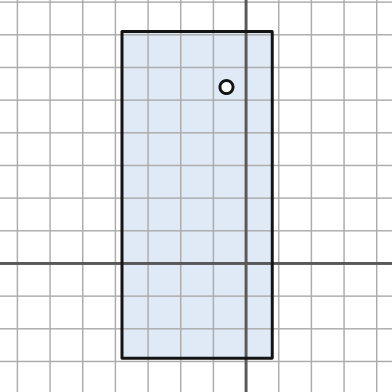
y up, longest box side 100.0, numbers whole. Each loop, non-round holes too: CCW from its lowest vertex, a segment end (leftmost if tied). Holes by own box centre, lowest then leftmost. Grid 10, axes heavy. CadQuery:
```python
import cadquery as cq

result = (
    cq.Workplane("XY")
    .moveTo(-38.0, -29.0)
    .lineTo(8.0, -29.0)
    .lineTo(8.0, 71.0)
    .lineTo(-38.0, 71.0)
    .close()
    .moveTo(-6.0, 54.0)
    .circle(2.0)
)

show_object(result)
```